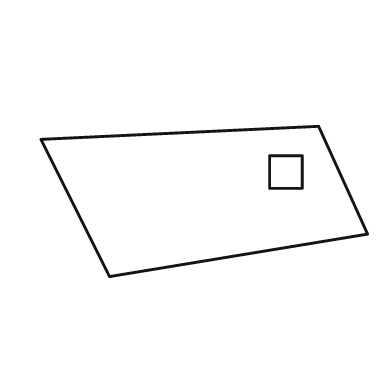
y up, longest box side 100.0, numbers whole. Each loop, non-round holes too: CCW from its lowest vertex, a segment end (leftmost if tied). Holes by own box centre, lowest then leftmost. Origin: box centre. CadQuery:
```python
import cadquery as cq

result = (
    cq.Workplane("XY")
    .moveTo(-29.0, -23.0)
    .lineTo(50.0, -10.0)
    .lineTo(35.0, 23.0)
    .lineTo(-50.0, 19.0)
    .close()
    .moveTo(20.0, 4.0)
    .lineTo(30.0, 4.0)
    .lineTo(30.0, 14.0)
    .lineTo(20.0, 14.0)
    .close()
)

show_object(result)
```